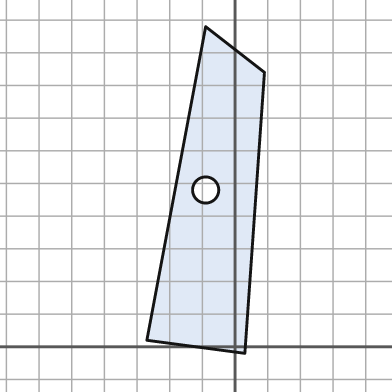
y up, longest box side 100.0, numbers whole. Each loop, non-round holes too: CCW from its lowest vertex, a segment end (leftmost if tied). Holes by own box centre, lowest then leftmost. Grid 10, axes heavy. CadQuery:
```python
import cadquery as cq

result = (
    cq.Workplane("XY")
    .moveTo(3.0, -2.0)
    .lineTo(9.0, 84.0)
    .lineTo(-9.0, 98.0)
    .lineTo(-27.0, 2.0)
    .close()
    .moveTo(-9.0, 48.0)
    .circle(4.0)
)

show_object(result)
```